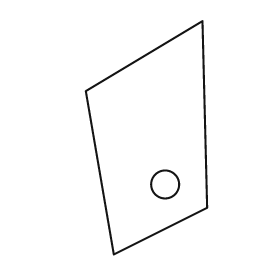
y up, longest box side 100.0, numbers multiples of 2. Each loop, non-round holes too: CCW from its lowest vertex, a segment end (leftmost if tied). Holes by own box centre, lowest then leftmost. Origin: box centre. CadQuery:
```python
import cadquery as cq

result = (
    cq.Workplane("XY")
    .moveTo(-14.0, -50.0)
    .lineTo(26.0, -30.0)
    .lineTo(24.0, 50.0)
    .lineTo(-26.0, 20.0)
    .close()
    .moveTo(8.0, -20.0)
    .circle(6.0)
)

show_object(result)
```